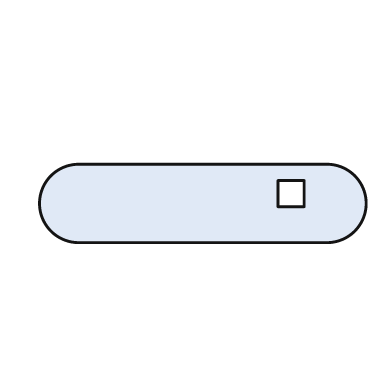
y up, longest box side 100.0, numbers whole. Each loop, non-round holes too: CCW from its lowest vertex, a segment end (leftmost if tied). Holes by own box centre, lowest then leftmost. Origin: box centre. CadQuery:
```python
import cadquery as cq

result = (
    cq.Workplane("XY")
    .moveTo(-38.0, -12.0)
    .lineTo(38.0, -12.0)
    .threePointArc((50.0, 0.0), (38.0, 12.0))
    .lineTo(-38.0, 12.0)
    .threePointArc((-50.0, 0.0), (-38.0, -12.0))
    .close()
    .moveTo(23.0, -1.0)
    .lineTo(31.0, -1.0)
    .lineTo(31.0, 7.0)
    .lineTo(23.0, 7.0)
    .close()
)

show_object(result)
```